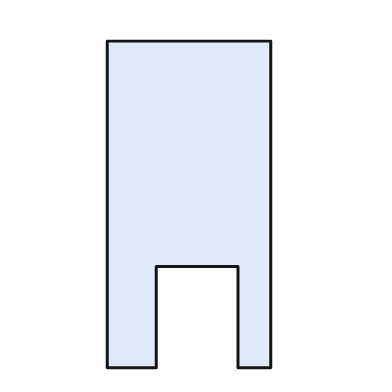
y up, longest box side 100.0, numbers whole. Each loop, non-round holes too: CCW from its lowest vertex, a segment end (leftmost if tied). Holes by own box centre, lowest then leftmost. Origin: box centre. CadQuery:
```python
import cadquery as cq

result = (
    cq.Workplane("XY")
    .moveTo(-25.0, -50.0)
    .lineTo(-10.0, -50.0)
    .lineTo(-10.0, -19.0)
    .lineTo(15.0, -19.0)
    .lineTo(15.0, -50.0)
    .lineTo(25.0, -50.0)
    .lineTo(25.0, 50.0)
    .lineTo(-25.0, 50.0)
    .close()
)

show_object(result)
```